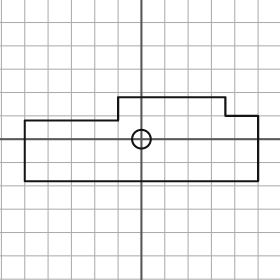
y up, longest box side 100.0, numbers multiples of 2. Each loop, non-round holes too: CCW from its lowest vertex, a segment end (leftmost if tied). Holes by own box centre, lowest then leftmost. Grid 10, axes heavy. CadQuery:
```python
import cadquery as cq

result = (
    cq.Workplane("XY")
    .moveTo(-50.0, -18.0)
    .lineTo(50.0, -18.0)
    .lineTo(50.0, 10.0)
    .lineTo(36.0, 10.0)
    .lineTo(36.0, 18.0)
    .lineTo(-10.0, 18.0)
    .lineTo(-10.0, 8.0)
    .lineTo(-50.0, 8.0)
    .close()
    .moveTo(0.0, 0.0)
    .circle(4.0)
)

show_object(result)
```